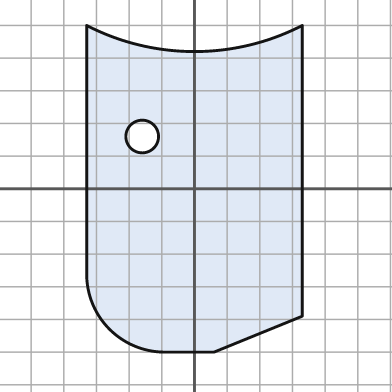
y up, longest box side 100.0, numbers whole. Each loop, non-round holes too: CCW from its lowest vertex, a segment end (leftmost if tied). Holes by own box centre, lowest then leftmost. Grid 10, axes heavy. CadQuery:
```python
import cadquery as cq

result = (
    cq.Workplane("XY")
    .moveTo(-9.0, -50.0)
    .lineTo(6.0, -50.0)
    .lineTo(33.0, -39.0)
    .lineTo(33.0, 50.0)
    .threePointArc((0.0, 42.0), (-33.0, 50.0))
    .lineTo(-33.0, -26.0)
    .threePointArc((-26.0, -43.0), (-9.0, -50.0))
    .close()
    .moveTo(-16.0, 16.0)
    .circle(5.0)
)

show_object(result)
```